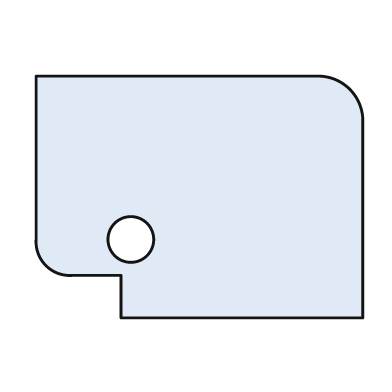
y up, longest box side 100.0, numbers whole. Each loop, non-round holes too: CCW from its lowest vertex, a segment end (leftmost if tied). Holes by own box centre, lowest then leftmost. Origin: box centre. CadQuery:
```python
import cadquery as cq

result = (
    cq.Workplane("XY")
    .moveTo(-24.0, -37.0)
    .lineTo(50.0, -37.0)
    .lineTo(50.0, 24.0)
    .threePointArc((46.0, 33.0), (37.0, 37.0))
    .lineTo(-50.0, 37.0)
    .lineTo(-50.0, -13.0)
    .threePointArc((-47.0, -21.0), (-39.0, -24.0))
    .lineTo(-24.0, -24.0)
    .close()
    .moveTo(-21.0, -13.0)
    .circle(7.0)
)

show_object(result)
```